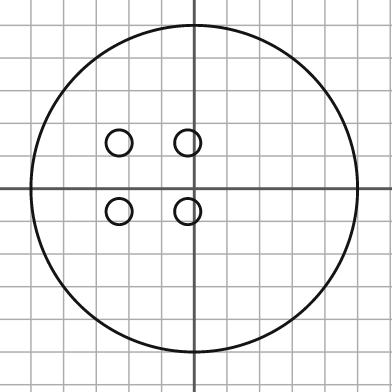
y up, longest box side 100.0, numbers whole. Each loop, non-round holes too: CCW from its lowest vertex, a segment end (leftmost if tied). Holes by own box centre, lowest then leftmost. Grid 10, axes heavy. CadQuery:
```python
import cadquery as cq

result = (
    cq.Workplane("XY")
    .moveTo(0.0, 0.0)
    .circle(50.0)
    .moveTo(-23.0, -7.0)
    .circle(4.0)
    .moveTo(-2.0, -7.0)
    .circle(4.0)
    .moveTo(-23.0, 14.0)
    .circle(4.0)
    .moveTo(-2.0, 14.0)
    .circle(4.0)
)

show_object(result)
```